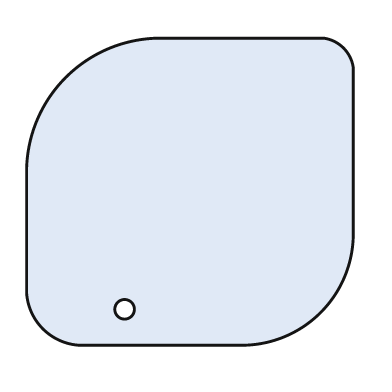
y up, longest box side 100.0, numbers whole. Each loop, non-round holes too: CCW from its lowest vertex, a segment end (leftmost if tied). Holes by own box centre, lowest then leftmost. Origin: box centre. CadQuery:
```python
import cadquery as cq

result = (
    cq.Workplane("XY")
    .moveTo(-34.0, -47.0)
    .lineTo(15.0, -47.0)
    .threePointArc((40.0, -37.0), (50.0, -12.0))
    .lineTo(50.0, 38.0)
    .threePointArc((47.0, 44.0), (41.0, 47.0))
    .lineTo(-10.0, 47.0)
    .threePointArc((-38.0, 35.0), (-50.0, 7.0))
    .lineTo(-50.0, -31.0)
    .threePointArc((-45.0, -42.0), (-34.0, -47.0))
    .close()
    .moveTo(-20.0, -36.0)
    .circle(3.0)
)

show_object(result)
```